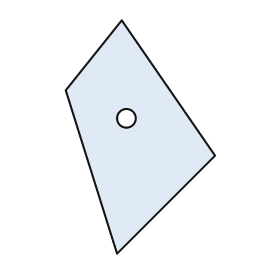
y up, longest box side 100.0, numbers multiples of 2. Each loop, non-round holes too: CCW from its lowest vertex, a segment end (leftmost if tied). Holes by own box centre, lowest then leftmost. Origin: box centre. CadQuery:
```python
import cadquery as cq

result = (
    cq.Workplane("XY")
    .moveTo(-10.0, -50.0)
    .lineTo(32.0, -8.0)
    .lineTo(-8.0, 50.0)
    .lineTo(-32.0, 20.0)
    .close()
    .moveTo(-6.0, 8.0)
    .circle(4.0)
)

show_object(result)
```